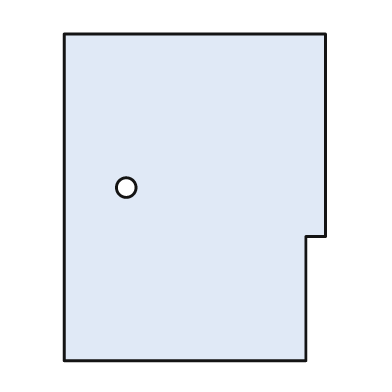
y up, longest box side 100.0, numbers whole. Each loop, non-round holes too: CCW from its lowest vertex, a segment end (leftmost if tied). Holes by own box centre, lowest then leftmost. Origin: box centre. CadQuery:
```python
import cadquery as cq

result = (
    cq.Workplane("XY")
    .moveTo(-40.0, -50.0)
    .lineTo(34.0, -50.0)
    .lineTo(34.0, -12.0)
    .lineTo(40.0, -12.0)
    .lineTo(40.0, 50.0)
    .lineTo(-40.0, 50.0)
    .close()
    .moveTo(-21.0, 3.0)
    .circle(3.0)
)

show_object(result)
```